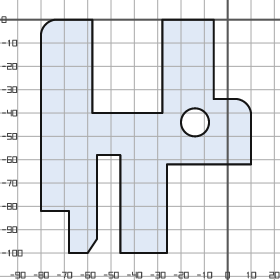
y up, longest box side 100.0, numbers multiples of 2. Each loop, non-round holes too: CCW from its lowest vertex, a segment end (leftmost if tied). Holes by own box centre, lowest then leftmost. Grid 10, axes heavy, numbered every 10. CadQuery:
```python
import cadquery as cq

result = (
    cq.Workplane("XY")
    .moveTo(-68.0, -100.0)
    .lineTo(-60.0, -100.0)
    .lineTo(-56.0, -94.0)
    .lineTo(-56.0, -58.0)
    .lineTo(-46.0, -58.0)
    .lineTo(-46.0, -100.0)
    .lineTo(-26.0, -100.0)
    .lineTo(-26.0, -62.0)
    .lineTo(10.0, -62.0)
    .lineTo(10.0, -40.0)
    .threePointArc((8.0, -36.0), (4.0, -34.0))
    .lineTo(-6.0, -34.0)
    .lineTo(-6.0, 0.0)
    .lineTo(-28.0, 0.0)
    .lineTo(-28.0, -40.0)
    .lineTo(-58.0, -40.0)
    .lineTo(-58.0, 0.0)
    .lineTo(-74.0, 0.0)
    .threePointArc((-78.0, -2.0), (-80.0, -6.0))
    .lineTo(-80.0, -82.0)
    .lineTo(-68.0, -82.0)
    .close()
    .moveTo(-14.0, -44.0)
    .circle(6.0)
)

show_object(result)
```